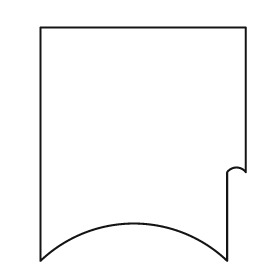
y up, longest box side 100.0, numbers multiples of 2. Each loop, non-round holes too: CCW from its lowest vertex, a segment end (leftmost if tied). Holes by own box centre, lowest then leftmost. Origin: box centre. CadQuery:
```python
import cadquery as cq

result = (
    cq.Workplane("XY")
    .moveTo(-44.0, -50.0)
    .threePointArc((-4.0, -34.0), (36.0, -50.0))
    .lineTo(36.0, -12.0)
    .threePointArc((40.0, -10.0), (44.0, -12.0))
    .lineTo(44.0, 50.0)
    .lineTo(-44.0, 50.0)
    .close()
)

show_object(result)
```